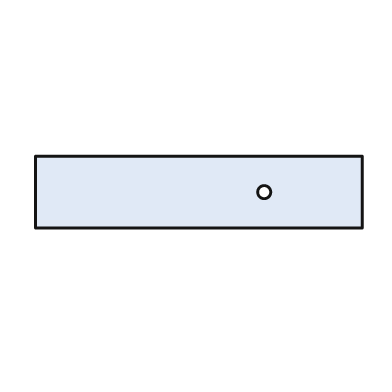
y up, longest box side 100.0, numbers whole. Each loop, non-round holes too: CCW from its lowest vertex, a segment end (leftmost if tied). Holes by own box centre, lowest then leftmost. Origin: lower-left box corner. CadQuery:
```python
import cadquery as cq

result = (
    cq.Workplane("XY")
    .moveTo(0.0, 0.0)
    .lineTo(100.0, 0.0)
    .lineTo(100.0, 22.0)
    .lineTo(0.0, 22.0)
    .close()
    .moveTo(70.0, 11.0)
    .circle(2.0)
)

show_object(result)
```